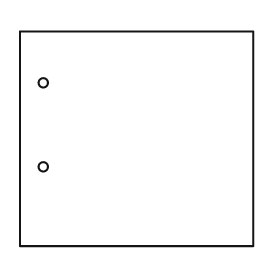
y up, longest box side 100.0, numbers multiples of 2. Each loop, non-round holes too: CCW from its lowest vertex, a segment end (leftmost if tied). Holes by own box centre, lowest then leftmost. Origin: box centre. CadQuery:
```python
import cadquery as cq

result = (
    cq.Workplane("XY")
    .moveTo(-50.0, -46.0)
    .lineTo(50.0, -46.0)
    .lineTo(50.0, 46.0)
    .lineTo(-50.0, 46.0)
    .close()
    .moveTo(-40.0, -12.0)
    .circle(2.0)
    .moveTo(-40.0, 24.0)
    .circle(2.0)
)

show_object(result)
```